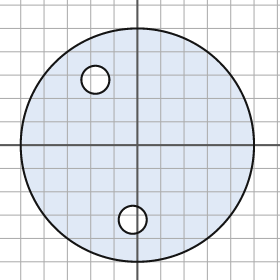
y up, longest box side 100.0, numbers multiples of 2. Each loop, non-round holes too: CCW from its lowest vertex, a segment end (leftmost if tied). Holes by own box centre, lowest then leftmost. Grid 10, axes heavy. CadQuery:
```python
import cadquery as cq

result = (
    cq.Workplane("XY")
    .moveTo(0.0, 0.0)
    .circle(50.0)
    .moveTo(-2.0, -32.0)
    .circle(6.0)
    .moveTo(-18.0, 28.0)
    .circle(6.0)
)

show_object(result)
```